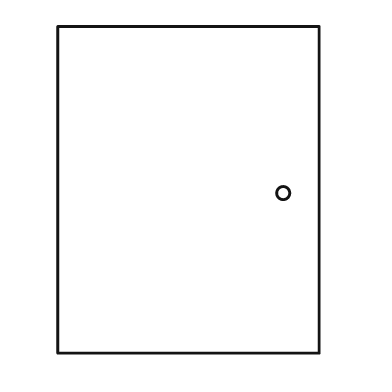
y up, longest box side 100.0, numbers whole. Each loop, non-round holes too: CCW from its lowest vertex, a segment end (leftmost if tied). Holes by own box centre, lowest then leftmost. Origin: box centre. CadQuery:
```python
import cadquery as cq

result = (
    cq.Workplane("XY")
    .moveTo(-40.0, -50.0)
    .lineTo(40.0, -50.0)
    .lineTo(40.0, 50.0)
    .lineTo(-40.0, 50.0)
    .close()
    .moveTo(29.0, -1.0)
    .circle(2.0)
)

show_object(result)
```